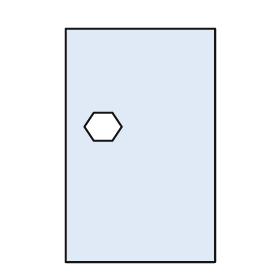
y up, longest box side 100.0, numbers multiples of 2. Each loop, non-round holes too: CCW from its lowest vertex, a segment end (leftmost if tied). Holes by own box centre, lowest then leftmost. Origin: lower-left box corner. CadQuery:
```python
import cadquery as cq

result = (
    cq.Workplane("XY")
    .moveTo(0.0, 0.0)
    .lineTo(64.0, 0.0)
    .lineTo(64.0, 100.0)
    .lineTo(0.0, 100.0)
    .close()
    .moveTo(12.0, 52.0)
    .lineTo(20.0, 52.0)
    .lineTo(24.0, 58.0)
    .lineTo(20.0, 64.0)
    .lineTo(12.0, 64.0)
    .lineTo(8.0, 58.0)
    .close()
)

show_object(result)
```